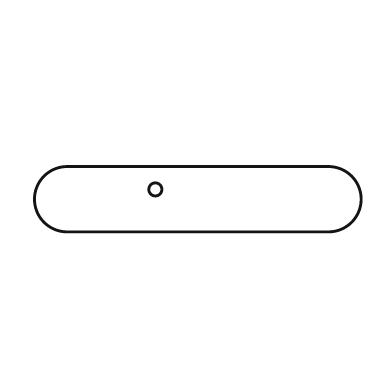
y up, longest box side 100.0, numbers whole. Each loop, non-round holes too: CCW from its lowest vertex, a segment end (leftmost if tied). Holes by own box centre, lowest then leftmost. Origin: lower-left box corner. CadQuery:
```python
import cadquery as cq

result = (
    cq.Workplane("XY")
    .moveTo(10.0, 0.0)
    .lineTo(90.0, 0.0)
    .threePointArc((100.0, 10.0), (90.0, 20.0))
    .lineTo(10.0, 20.0)
    .threePointArc((0.0, 10.0), (10.0, 0.0))
    .close()
    .moveTo(37.0, 13.0)
    .circle(2.0)
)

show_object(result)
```